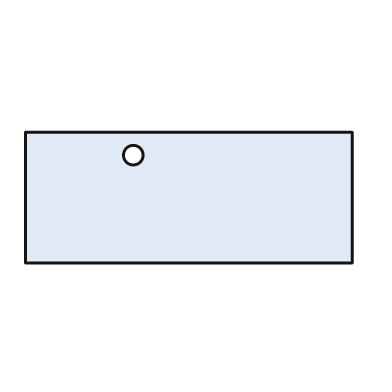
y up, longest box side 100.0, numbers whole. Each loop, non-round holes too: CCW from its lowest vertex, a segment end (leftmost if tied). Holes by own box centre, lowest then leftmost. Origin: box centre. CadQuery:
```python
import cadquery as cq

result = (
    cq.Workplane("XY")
    .moveTo(-50.0, -20.0)
    .lineTo(50.0, -20.0)
    .lineTo(50.0, 20.0)
    .lineTo(-50.0, 20.0)
    .close()
    .moveTo(-17.0, 13.0)
    .circle(3.0)
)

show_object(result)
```